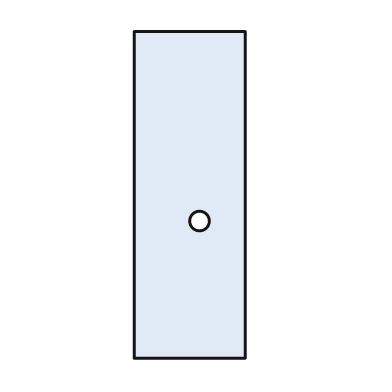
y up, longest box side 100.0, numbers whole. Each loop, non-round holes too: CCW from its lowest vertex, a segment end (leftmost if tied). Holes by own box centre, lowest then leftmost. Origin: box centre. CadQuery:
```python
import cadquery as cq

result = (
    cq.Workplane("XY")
    .moveTo(-17.0, -50.0)
    .lineTo(17.0, -50.0)
    .lineTo(17.0, 50.0)
    .lineTo(-17.0, 50.0)
    .close()
    .moveTo(3.0, -8.0)
    .circle(3.0)
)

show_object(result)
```